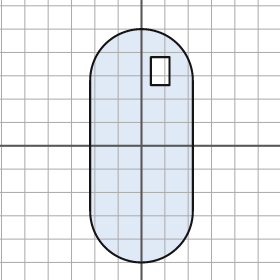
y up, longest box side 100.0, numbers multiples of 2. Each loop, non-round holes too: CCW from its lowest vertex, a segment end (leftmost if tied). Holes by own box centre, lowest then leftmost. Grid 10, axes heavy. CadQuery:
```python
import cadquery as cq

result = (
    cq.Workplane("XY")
    .moveTo(-22.0, -28.0)
    .threePointArc((0.0, -50.0), (22.0, -28.0))
    .lineTo(22.0, 28.0)
    .threePointArc((0.0, 50.0), (-22.0, 28.0))
    .close()
    .moveTo(4.0, 26.0)
    .lineTo(12.0, 26.0)
    .lineTo(12.0, 38.0)
    .lineTo(4.0, 38.0)
    .close()
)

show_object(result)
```